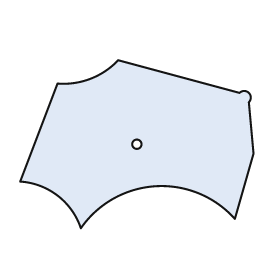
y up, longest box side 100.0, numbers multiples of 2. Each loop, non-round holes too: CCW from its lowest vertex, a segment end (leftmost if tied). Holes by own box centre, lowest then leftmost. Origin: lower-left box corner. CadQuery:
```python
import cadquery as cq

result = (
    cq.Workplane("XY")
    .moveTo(26.0, 0.0)
    .threePointArc((58.0, 18.0), (92.0, 4.0))
    .lineTo(100.0, 32.0)
    .lineTo(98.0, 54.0)
    .threePointArc((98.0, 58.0), (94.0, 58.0))
    .lineTo(42.0, 72.0)
    .threePointArc((30.0, 64.0), (16.0, 62.0))
    .lineTo(0.0, 20.0)
    .threePointArc((16.0, 14.0), (26.0, 0.0))
    .close()
    .moveTo(50.0, 36.0)
    .circle(2.0)
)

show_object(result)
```